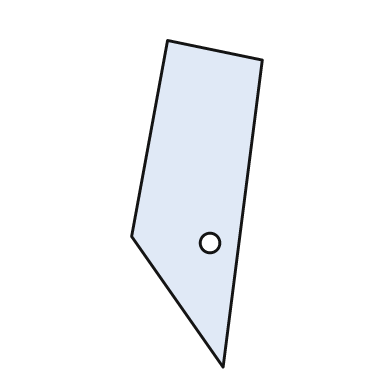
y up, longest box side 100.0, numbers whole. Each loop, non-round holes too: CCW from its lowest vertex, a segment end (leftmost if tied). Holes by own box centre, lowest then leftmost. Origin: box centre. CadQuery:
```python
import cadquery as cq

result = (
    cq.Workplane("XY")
    .moveTo(8.0, -50.0)
    .lineTo(20.0, 44.0)
    .lineTo(-9.0, 50.0)
    .lineTo(-20.0, -10.0)
    .close()
    .moveTo(4.0, -12.0)
    .circle(3.0)
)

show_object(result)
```